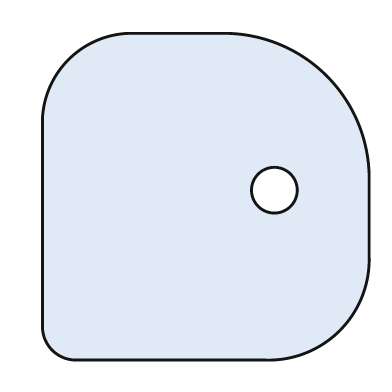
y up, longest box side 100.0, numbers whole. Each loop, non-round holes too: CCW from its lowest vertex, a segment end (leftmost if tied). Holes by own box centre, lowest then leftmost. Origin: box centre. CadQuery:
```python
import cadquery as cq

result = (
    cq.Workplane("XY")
    .moveTo(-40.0, -50.0)
    .lineTo(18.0, -50.0)
    .threePointArc((41.0, -41.0), (50.0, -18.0))
    .lineTo(50.0, 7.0)
    .threePointArc((37.0, 37.0), (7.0, 50.0))
    .lineTo(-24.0, 50.0)
    .threePointArc((-42.0, 42.0), (-50.0, 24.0))
    .lineTo(-50.0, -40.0)
    .threePointArc((-47.0, -47.0), (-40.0, -50.0))
    .close()
    .moveTo(21.0, 2.0)
    .circle(7.0)
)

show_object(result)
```